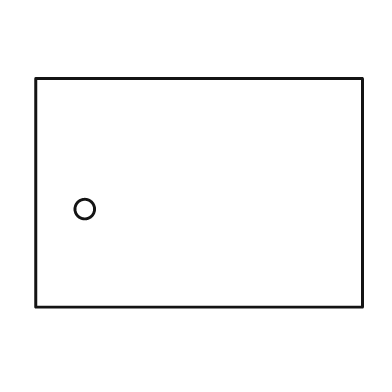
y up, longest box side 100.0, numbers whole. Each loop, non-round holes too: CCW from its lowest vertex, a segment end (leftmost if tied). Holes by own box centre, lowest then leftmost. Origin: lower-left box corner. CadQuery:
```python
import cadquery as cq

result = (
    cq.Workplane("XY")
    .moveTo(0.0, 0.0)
    .lineTo(100.0, 0.0)
    .lineTo(100.0, 70.0)
    .lineTo(0.0, 70.0)
    .close()
    .moveTo(15.0, 30.0)
    .circle(3.0)
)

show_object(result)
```